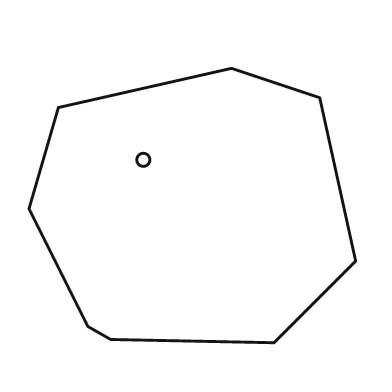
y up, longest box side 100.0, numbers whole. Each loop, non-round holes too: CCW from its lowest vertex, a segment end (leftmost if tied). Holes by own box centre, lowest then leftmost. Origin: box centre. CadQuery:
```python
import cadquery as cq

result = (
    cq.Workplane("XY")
    .moveTo(25.0, -42.0)
    .lineTo(50.0, -17.0)
    .lineTo(39.0, 33.0)
    .lineTo(12.0, 42.0)
    .lineTo(-41.0, 30.0)
    .lineTo(-50.0, -1.0)
    .lineTo(-32.0, -37.0)
    .lineTo(-25.0, -41.0)
    .close()
    .moveTo(-15.0, 14.0)
    .circle(2.0)
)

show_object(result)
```